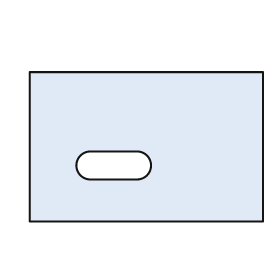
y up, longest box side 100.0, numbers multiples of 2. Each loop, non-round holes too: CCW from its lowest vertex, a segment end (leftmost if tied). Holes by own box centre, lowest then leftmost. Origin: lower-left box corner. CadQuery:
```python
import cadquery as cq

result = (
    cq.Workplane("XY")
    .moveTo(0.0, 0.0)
    .lineTo(100.0, 0.0)
    .lineTo(100.0, 64.0)
    .lineTo(0.0, 64.0)
    .close()
    .moveTo(26.0, 18.0)
    .lineTo(46.0, 18.0)
    .threePointArc((52.0, 24.0), (46.0, 30.0))
    .lineTo(26.0, 30.0)
    .threePointArc((20.0, 24.0), (26.0, 18.0))
    .close()
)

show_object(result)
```